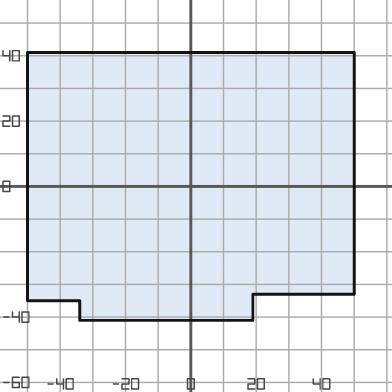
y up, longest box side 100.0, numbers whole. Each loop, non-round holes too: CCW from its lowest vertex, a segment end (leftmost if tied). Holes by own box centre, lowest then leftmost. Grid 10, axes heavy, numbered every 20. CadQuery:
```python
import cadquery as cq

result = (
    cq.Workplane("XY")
    .moveTo(-34.0, -41.0)
    .lineTo(19.0, -41.0)
    .lineTo(19.0, -33.0)
    .lineTo(50.0, -33.0)
    .lineTo(50.0, 41.0)
    .lineTo(-50.0, 41.0)
    .lineTo(-50.0, -35.0)
    .lineTo(-34.0, -35.0)
    .close()
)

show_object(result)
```